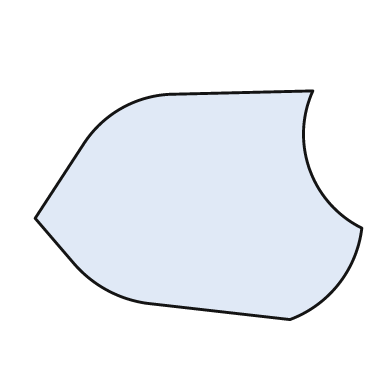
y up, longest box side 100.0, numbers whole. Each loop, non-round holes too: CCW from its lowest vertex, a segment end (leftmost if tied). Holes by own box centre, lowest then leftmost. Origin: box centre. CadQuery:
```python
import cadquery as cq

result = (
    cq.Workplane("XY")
    .moveTo(28.0, -35.0)
    .threePointArc((43.0, -24.0), (50.0, -7.0))
    .threePointArc((34.0, 11.0), (35.0, 35.0))
    .lineTo(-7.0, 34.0)
    .threePointArc((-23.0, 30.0), (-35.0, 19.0))
    .lineTo(-50.0, -4.0)
    .lineTo(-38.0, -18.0)
    .threePointArc((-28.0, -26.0), (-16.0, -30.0))
    .close()
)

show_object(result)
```